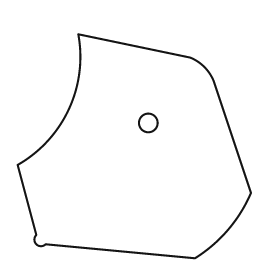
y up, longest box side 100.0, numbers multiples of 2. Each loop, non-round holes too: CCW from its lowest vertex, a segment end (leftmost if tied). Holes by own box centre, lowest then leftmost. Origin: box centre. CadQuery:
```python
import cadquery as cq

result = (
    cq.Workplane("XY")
    .moveTo(26.0, -48.0)
    .threePointArc((40.0, -36.0), (50.0, -20.0))
    .lineTo(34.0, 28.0)
    .threePointArc((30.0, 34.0), (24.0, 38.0))
    .lineTo(-24.0, 48.0)
    .threePointArc((-28.0, 16.0), (-50.0, -8.0))
    .lineTo(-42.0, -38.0)
    .threePointArc((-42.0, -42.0), (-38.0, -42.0))
    .close()
    .moveTo(6.0, 10.0)
    .circle(4.0)
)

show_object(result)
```